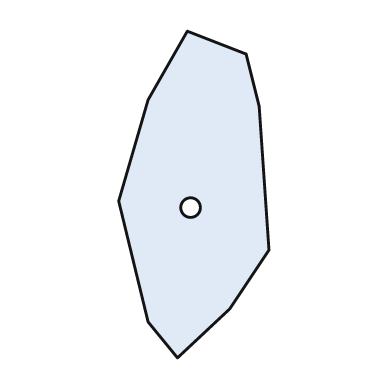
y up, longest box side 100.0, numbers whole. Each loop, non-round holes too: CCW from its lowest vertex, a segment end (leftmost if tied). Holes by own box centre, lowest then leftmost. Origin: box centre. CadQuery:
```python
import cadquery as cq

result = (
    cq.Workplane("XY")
    .moveTo(-5.0, -50.0)
    .lineTo(11.0, -35.0)
    .lineTo(23.0, -17.0)
    .lineTo(20.0, 27.0)
    .lineTo(16.0, 43.0)
    .lineTo(-2.0, 50.0)
    .lineTo(-14.0, 29.0)
    .lineTo(-23.0, -2.0)
    .lineTo(-14.0, -39.0)
    .close()
    .moveTo(-1.0, -4.0)
    .circle(3.0)
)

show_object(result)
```